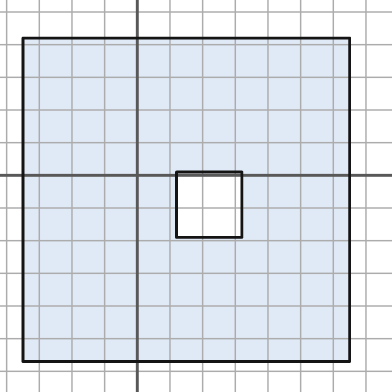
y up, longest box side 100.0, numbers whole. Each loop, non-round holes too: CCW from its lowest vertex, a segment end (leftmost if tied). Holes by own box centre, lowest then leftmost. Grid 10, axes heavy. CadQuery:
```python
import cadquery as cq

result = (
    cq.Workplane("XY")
    .moveTo(-35.0, -57.0)
    .lineTo(65.0, -57.0)
    .lineTo(65.0, 42.0)
    .lineTo(-35.0, 42.0)
    .close()
    .moveTo(12.0, -19.0)
    .lineTo(32.0, -19.0)
    .lineTo(32.0, 1.0)
    .lineTo(12.0, 1.0)
    .close()
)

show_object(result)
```